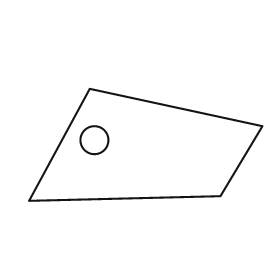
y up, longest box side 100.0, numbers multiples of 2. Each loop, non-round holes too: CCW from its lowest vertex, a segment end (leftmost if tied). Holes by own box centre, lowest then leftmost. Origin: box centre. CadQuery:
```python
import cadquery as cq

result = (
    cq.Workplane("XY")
    .moveTo(-50.0, -24.0)
    .lineTo(32.0, -22.0)
    .lineTo(50.0, 8.0)
    .lineTo(-24.0, 24.0)
    .close()
    .moveTo(-22.0, 2.0)
    .circle(6.0)
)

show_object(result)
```